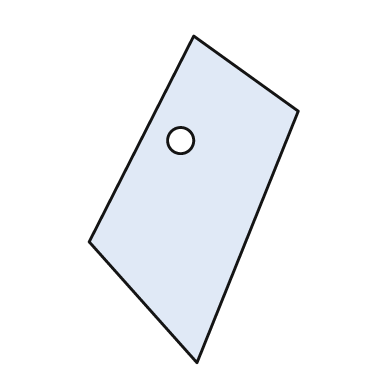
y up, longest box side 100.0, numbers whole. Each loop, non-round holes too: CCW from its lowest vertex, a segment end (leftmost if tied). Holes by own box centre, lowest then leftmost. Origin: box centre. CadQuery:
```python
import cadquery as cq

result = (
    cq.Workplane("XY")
    .moveTo(1.0, -50.0)
    .lineTo(32.0, 27.0)
    .lineTo(0.0, 50.0)
    .lineTo(-32.0, -13.0)
    .close()
    .moveTo(-4.0, 18.0)
    .circle(4.0)
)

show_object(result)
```